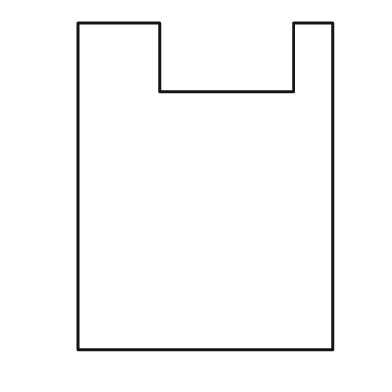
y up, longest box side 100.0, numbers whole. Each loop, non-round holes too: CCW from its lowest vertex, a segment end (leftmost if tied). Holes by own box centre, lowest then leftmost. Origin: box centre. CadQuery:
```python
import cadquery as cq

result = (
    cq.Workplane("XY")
    .moveTo(-39.0, -50.0)
    .lineTo(39.0, -50.0)
    .lineTo(39.0, 50.0)
    .lineTo(27.0, 50.0)
    .lineTo(27.0, 29.0)
    .lineTo(-14.0, 29.0)
    .lineTo(-14.0, 50.0)
    .lineTo(-39.0, 50.0)
    .close()
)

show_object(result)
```